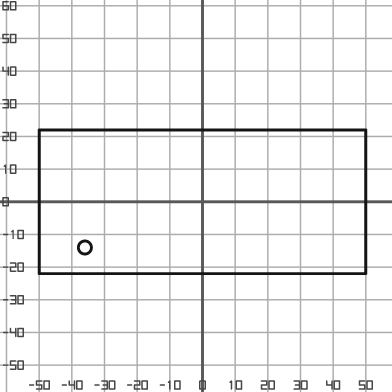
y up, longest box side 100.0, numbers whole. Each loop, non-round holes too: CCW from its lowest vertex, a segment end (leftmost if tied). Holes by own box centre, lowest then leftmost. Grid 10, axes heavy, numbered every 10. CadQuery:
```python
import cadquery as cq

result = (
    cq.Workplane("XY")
    .moveTo(-50.0, -22.0)
    .lineTo(50.0, -22.0)
    .lineTo(50.0, 22.0)
    .lineTo(-50.0, 22.0)
    .close()
    .moveTo(-36.0, -14.0)
    .circle(2.0)
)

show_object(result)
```